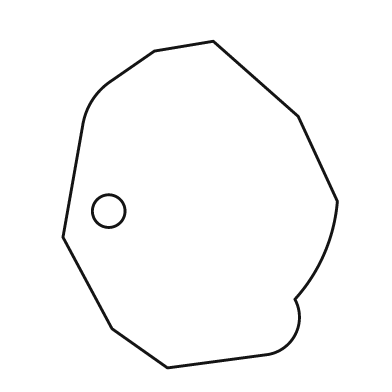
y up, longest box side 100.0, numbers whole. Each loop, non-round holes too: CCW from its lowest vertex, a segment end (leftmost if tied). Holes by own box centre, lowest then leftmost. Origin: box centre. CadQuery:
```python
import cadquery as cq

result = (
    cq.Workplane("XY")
    .moveTo(-10.0, -50.0)
    .lineTo(20.0, -46.0)
    .threePointArc((29.0, -40.0), (29.0, -29.0))
    .threePointArc((38.0, -15.0), (42.0, 1.0))
    .lineTo(30.0, 27.0)
    .lineTo(4.0, 50.0)
    .lineTo(-14.0, 47.0)
    .lineTo(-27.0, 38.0)
    .threePointArc((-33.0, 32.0), (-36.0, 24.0))
    .lineTo(-42.0, -10.0)
    .lineTo(-27.0, -38.0)
    .close()
    .moveTo(-28.0, -2.0)
    .circle(5.0)
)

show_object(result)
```